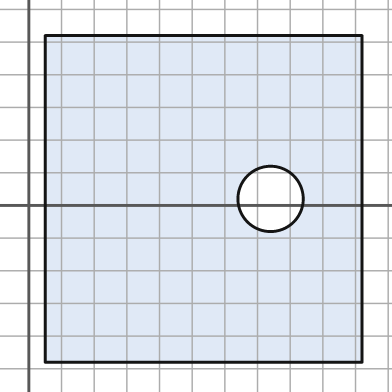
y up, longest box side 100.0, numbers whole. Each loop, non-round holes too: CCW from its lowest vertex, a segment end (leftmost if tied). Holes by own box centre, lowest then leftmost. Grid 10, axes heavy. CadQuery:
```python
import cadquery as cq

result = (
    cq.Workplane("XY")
    .moveTo(5.0, -48.0)
    .lineTo(102.0, -48.0)
    .lineTo(102.0, 52.0)
    .lineTo(5.0, 52.0)
    .close()
    .moveTo(74.0, 2.0)
    .circle(10.0)
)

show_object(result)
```